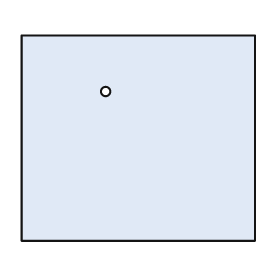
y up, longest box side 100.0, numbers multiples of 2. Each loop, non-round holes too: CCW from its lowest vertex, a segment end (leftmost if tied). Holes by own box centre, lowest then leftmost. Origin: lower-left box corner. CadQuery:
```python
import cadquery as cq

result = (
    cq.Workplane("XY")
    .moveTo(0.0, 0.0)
    .lineTo(100.0, 0.0)
    .lineTo(100.0, 88.0)
    .lineTo(0.0, 88.0)
    .close()
    .moveTo(36.0, 64.0)
    .circle(2.0)
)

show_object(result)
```